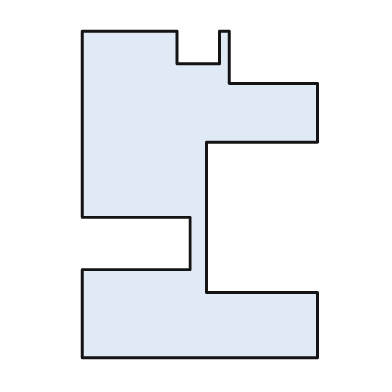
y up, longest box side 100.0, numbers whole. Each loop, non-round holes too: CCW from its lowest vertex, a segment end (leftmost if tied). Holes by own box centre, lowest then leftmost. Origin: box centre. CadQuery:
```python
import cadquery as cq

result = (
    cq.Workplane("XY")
    .moveTo(-36.0, -50.0)
    .lineTo(36.0, -50.0)
    .lineTo(36.0, -30.0)
    .lineTo(2.0, -30.0)
    .lineTo(2.0, 16.0)
    .lineTo(36.0, 16.0)
    .lineTo(36.0, 34.0)
    .lineTo(9.0, 34.0)
    .lineTo(9.0, 50.0)
    .lineTo(6.0, 50.0)
    .lineTo(6.0, 40.0)
    .lineTo(-7.0, 40.0)
    .lineTo(-7.0, 50.0)
    .lineTo(-36.0, 50.0)
    .lineTo(-36.0, -7.0)
    .lineTo(-3.0, -7.0)
    .lineTo(-3.0, -23.0)
    .lineTo(-36.0, -23.0)
    .close()
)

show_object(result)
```